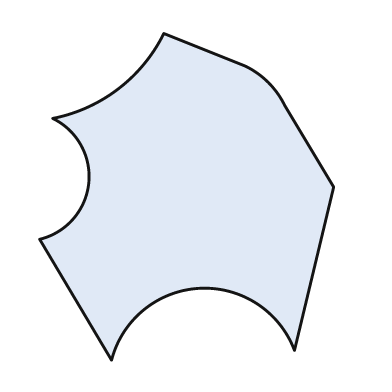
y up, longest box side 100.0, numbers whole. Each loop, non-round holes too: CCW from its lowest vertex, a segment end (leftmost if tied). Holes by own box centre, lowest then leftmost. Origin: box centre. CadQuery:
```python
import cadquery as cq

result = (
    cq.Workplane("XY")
    .moveTo(-23.0, -50.0)
    .threePointArc((4.0, -28.0), (33.0, -47.0))
    .lineTo(45.0, 3.0)
    .lineTo(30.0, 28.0)
    .threePointArc((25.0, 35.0), (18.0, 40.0))
    .lineTo(-7.0, 50.0)
    .threePointArc((-21.0, 33.0), (-41.0, 24.0))
    .threePointArc((-30.0, 4.0), (-45.0, -13.0))
    .close()
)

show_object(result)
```